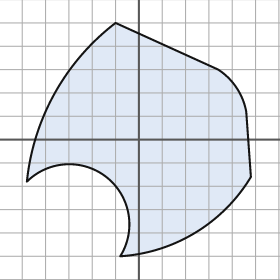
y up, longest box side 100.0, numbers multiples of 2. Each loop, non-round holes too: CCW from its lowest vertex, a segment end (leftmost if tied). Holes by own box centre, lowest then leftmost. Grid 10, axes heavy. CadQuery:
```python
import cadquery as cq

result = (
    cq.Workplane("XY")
    .moveTo(-8.0, -50.0)
    .threePointArc((24.0, -40.0), (48.0, -16.0))
    .lineTo(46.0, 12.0)
    .threePointArc((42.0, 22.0), (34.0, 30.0))
    .lineTo(-10.0, 50.0)
    .threePointArc((-36.0, 20.0), (-48.0, -18.0))
    .threePointArc((-14.0, -16.0), (-8.0, -50.0))
    .close()
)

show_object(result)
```